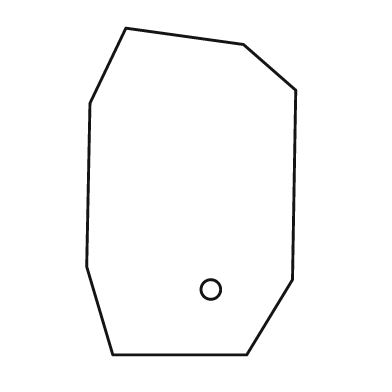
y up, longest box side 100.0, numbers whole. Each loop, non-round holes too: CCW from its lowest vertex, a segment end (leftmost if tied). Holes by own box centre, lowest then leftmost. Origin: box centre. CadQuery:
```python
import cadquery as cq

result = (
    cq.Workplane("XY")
    .moveTo(-24.0, -50.0)
    .lineTo(17.0, -50.0)
    .lineTo(31.0, -27.0)
    .lineTo(32.0, 31.0)
    .lineTo(16.0, 45.0)
    .lineTo(-20.0, 50.0)
    .lineTo(-31.0, 27.0)
    .lineTo(-32.0, -23.0)
    .close()
    .moveTo(6.0, -30.0)
    .circle(3.0)
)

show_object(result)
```